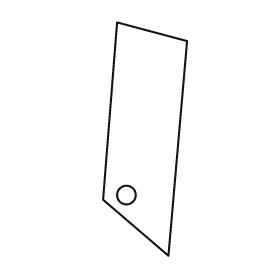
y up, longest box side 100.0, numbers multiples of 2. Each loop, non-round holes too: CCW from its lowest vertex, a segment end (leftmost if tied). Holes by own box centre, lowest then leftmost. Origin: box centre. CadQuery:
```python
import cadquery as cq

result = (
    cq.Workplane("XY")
    .moveTo(10.0, -50.0)
    .lineTo(18.0, 42.0)
    .lineTo(-12.0, 50.0)
    .lineTo(-18.0, -26.0)
    .close()
    .moveTo(-8.0, -24.0)
    .circle(4.0)
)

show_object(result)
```